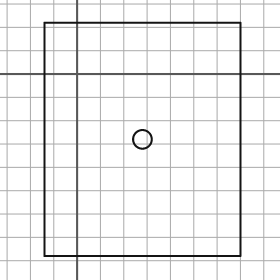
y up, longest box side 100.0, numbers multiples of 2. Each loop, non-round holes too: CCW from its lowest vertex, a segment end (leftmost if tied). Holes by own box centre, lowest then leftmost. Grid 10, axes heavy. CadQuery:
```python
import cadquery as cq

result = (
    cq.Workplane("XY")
    .moveTo(-14.0, -78.0)
    .lineTo(70.0, -78.0)
    .lineTo(70.0, 22.0)
    .lineTo(-14.0, 22.0)
    .close()
    .moveTo(28.0, -28.0)
    .circle(4.0)
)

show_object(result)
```